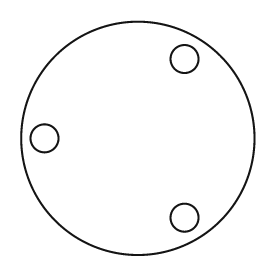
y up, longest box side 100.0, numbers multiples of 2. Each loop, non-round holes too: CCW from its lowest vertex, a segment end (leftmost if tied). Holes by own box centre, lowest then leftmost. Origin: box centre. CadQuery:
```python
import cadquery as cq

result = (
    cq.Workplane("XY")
    .moveTo(0.0, 0.0)
    .circle(50.0)
    .moveTo(20.0, -34.0)
    .circle(6.0)
    .moveTo(-40.0, 0.0)
    .circle(6.0)
    .moveTo(20.0, 34.0)
    .circle(6.0)
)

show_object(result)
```